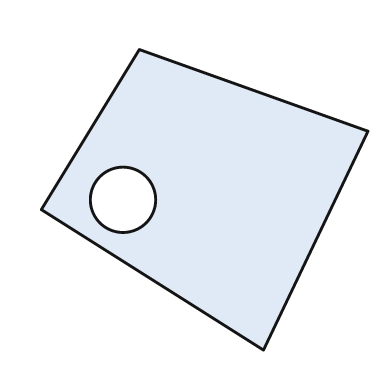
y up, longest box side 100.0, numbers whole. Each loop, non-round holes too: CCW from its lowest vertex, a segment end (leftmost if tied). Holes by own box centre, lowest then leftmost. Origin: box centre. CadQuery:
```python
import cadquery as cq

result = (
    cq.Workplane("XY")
    .moveTo(18.0, -46.0)
    .lineTo(50.0, 21.0)
    .lineTo(-20.0, 46.0)
    .lineTo(-50.0, -3.0)
    .close()
    .moveTo(-25.0, 0.0)
    .circle(10.0)
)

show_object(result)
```